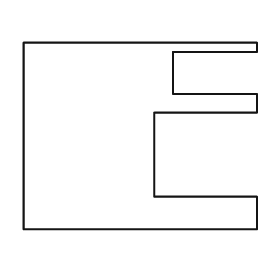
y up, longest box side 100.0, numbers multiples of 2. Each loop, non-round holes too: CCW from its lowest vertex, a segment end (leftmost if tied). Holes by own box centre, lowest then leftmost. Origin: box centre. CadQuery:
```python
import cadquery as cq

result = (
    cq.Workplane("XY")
    .moveTo(-50.0, -40.0)
    .lineTo(50.0, -40.0)
    .lineTo(50.0, -26.0)
    .lineTo(6.0, -26.0)
    .lineTo(6.0, 10.0)
    .lineTo(50.0, 10.0)
    .lineTo(50.0, 18.0)
    .lineTo(14.0, 18.0)
    .lineTo(14.0, 36.0)
    .lineTo(50.0, 36.0)
    .lineTo(50.0, 40.0)
    .lineTo(-50.0, 40.0)
    .close()
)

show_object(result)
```